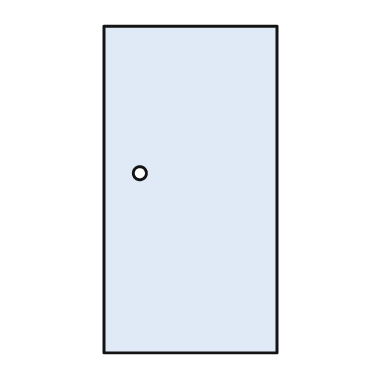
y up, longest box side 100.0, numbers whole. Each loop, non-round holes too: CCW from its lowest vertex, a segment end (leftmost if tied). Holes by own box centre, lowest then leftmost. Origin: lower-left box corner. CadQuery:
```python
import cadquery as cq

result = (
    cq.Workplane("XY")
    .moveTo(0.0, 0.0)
    .lineTo(53.0, 0.0)
    .lineTo(53.0, 100.0)
    .lineTo(0.0, 100.0)
    .close()
    .moveTo(11.0, 55.0)
    .circle(2.0)
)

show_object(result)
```